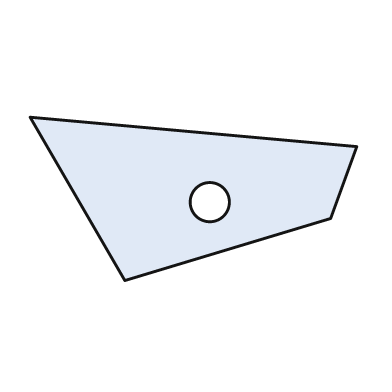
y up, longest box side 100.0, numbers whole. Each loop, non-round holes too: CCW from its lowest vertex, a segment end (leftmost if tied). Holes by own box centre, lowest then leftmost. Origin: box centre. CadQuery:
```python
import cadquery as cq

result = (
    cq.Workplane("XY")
    .moveTo(-21.0, -25.0)
    .lineTo(42.0, -6.0)
    .lineTo(50.0, 16.0)
    .lineTo(-50.0, 25.0)
    .close()
    .moveTo(5.0, -1.0)
    .circle(6.0)
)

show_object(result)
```